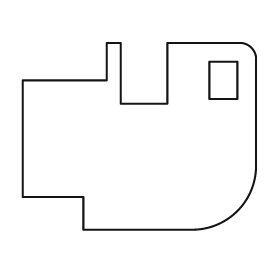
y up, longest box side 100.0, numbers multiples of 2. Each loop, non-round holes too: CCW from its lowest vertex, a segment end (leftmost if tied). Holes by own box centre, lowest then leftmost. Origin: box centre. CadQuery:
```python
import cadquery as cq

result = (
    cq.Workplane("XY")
    .moveTo(-24.0, -40.0)
    .lineTo(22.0, -40.0)
    .threePointArc((42.0, -32.0), (50.0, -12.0))
    .lineTo(50.0, 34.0)
    .threePointArc((48.0, 38.0), (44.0, 40.0))
    .lineTo(12.0, 40.0)
    .lineTo(12.0, 14.0)
    .lineTo(-8.0, 14.0)
    .lineTo(-8.0, 40.0)
    .lineTo(-14.0, 40.0)
    .lineTo(-14.0, 24.0)
    .lineTo(-50.0, 24.0)
    .lineTo(-50.0, -26.0)
    .lineTo(-24.0, -26.0)
    .close()
    .moveTo(30.0, 16.0)
    .lineTo(42.0, 16.0)
    .lineTo(42.0, 32.0)
    .lineTo(30.0, 32.0)
    .close()
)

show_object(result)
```